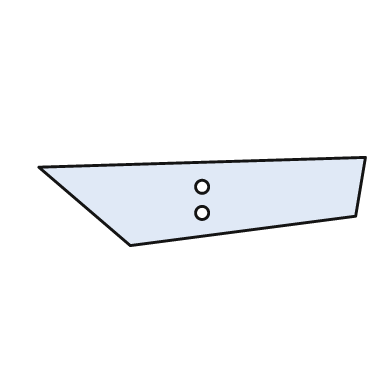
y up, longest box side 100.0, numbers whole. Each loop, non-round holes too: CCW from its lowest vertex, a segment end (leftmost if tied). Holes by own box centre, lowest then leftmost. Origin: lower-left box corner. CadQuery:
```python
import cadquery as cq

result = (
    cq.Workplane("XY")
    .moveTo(28.0, 0.0)
    .lineTo(97.0, 9.0)
    .lineTo(100.0, 27.0)
    .lineTo(0.0, 24.0)
    .close()
    .moveTo(50.0, 10.0)
    .circle(2.0)
    .moveTo(50.0, 18.0)
    .circle(2.0)
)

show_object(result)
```